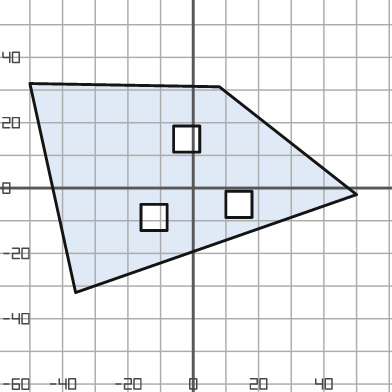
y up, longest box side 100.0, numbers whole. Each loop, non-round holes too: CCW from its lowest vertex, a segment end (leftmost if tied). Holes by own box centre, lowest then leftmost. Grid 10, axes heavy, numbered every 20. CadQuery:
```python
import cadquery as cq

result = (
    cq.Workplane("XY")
    .moveTo(-36.0, -32.0)
    .lineTo(50.0, -2.0)
    .lineTo(8.0, 31.0)
    .lineTo(-50.0, 32.0)
    .close()
    .moveTo(-16.0, -13.0)
    .lineTo(-8.0, -13.0)
    .lineTo(-8.0, -5.0)
    .lineTo(-16.0, -5.0)
    .close()
    .moveTo(10.0, -9.0)
    .lineTo(18.0, -9.0)
    .lineTo(18.0, -1.0)
    .lineTo(10.0, -1.0)
    .close()
    .moveTo(-6.0, 11.0)
    .lineTo(2.0, 11.0)
    .lineTo(2.0, 19.0)
    .lineTo(-6.0, 19.0)
    .close()
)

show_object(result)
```